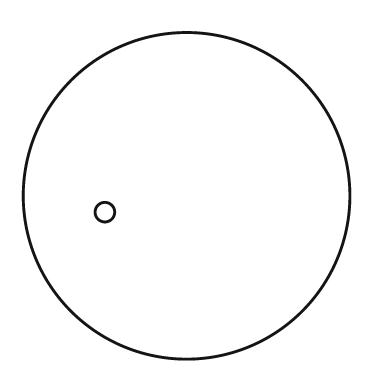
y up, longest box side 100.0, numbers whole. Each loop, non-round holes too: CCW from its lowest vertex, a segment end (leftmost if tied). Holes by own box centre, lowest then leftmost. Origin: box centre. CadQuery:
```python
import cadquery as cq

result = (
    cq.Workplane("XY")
    .moveTo(0.0, 0.0)
    .circle(50.0)
    .moveTo(-25.0, -5.0)
    .circle(3.0)
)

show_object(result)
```